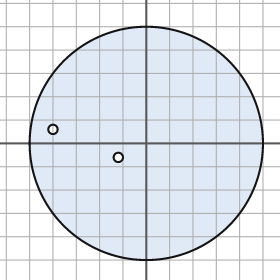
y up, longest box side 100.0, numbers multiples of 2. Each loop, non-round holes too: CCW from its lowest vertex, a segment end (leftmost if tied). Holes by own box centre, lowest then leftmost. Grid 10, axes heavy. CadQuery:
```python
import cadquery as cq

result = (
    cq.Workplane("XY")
    .moveTo(0.0, 0.0)
    .circle(50.0)
    .moveTo(-12.0, -6.0)
    .circle(2.0)
    .moveTo(-40.0, 6.0)
    .circle(2.0)
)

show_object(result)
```